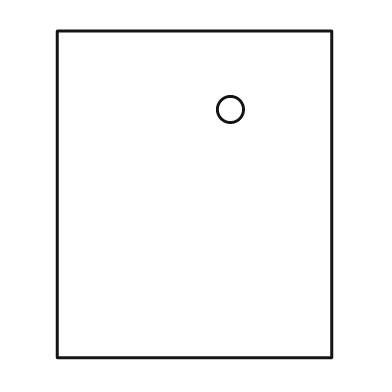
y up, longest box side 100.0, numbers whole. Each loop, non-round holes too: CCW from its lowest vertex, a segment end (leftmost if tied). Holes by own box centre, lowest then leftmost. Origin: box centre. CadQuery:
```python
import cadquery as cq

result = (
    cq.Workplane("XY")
    .moveTo(-42.0, -50.0)
    .lineTo(42.0, -50.0)
    .lineTo(42.0, 50.0)
    .lineTo(-42.0, 50.0)
    .close()
    .moveTo(11.0, 26.0)
    .circle(4.0)
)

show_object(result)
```